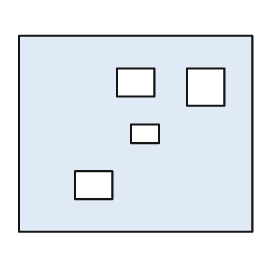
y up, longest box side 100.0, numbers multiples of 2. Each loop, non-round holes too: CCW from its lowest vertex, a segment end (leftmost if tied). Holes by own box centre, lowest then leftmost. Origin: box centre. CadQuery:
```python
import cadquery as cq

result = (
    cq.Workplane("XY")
    .moveTo(-50.0, -42.0)
    .lineTo(50.0, -42.0)
    .lineTo(50.0, 42.0)
    .lineTo(-50.0, 42.0)
    .close()
    .moveTo(-26.0, -28.0)
    .lineTo(-10.0, -28.0)
    .lineTo(-10.0, -16.0)
    .lineTo(-26.0, -16.0)
    .close()
    .moveTo(-2.0, -4.0)
    .lineTo(10.0, -4.0)
    .lineTo(10.0, 4.0)
    .lineTo(-2.0, 4.0)
    .close()
    .moveTo(22.0, 12.0)
    .lineTo(38.0, 12.0)
    .lineTo(38.0, 28.0)
    .lineTo(22.0, 28.0)
    .close()
    .moveTo(-8.0, 16.0)
    .lineTo(8.0, 16.0)
    .lineTo(8.0, 28.0)
    .lineTo(-8.0, 28.0)
    .close()
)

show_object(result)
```